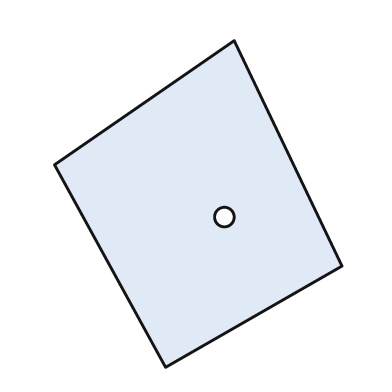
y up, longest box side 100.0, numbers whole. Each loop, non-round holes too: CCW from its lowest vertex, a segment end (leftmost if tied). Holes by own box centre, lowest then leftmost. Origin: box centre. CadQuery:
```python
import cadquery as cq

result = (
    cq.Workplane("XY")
    .moveTo(-10.0, -50.0)
    .lineTo(44.0, -19.0)
    .lineTo(11.0, 50.0)
    .lineTo(-44.0, 12.0)
    .close()
    .moveTo(8.0, -4.0)
    .circle(3.0)
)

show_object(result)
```